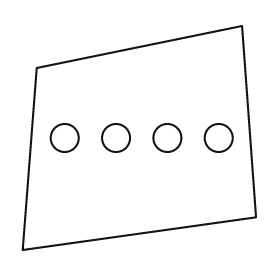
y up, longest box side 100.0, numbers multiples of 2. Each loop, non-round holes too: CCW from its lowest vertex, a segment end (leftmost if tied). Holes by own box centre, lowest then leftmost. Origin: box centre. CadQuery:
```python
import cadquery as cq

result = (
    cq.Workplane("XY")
    .moveTo(-50.0, -48.0)
    .lineTo(50.0, -34.0)
    .lineTo(44.0, 48.0)
    .lineTo(-44.0, 30.0)
    .close()
    .moveTo(-32.0, 0.0)
    .circle(6.0)
    .moveTo(-10.0, 0.0)
    .circle(6.0)
    .moveTo(12.0, 0.0)
    .circle(6.0)
    .moveTo(34.0, 0.0)
    .circle(6.0)
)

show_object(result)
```